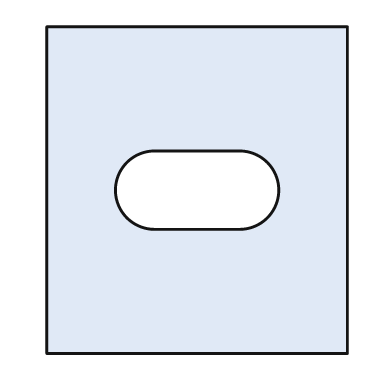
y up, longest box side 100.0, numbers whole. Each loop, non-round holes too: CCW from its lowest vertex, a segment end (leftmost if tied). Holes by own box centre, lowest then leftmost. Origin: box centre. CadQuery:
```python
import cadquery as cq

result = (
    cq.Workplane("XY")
    .moveTo(-46.0, -50.0)
    .lineTo(46.0, -50.0)
    .lineTo(46.0, 50.0)
    .lineTo(-46.0, 50.0)
    .close()
    .moveTo(-13.0, -12.0)
    .lineTo(13.0, -12.0)
    .threePointArc((25.0, 0.0), (13.0, 12.0))
    .lineTo(-13.0, 12.0)
    .threePointArc((-25.0, 0.0), (-13.0, -12.0))
    .close()
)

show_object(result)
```